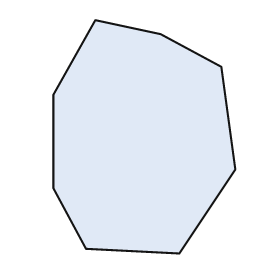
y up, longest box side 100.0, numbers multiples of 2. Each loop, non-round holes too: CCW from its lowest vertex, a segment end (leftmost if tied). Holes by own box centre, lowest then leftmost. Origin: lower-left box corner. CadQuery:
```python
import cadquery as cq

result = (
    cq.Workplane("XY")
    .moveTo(54.0, 0.0)
    .lineTo(78.0, 36.0)
    .lineTo(72.0, 80.0)
    .lineTo(46.0, 94.0)
    .lineTo(18.0, 100.0)
    .lineTo(0.0, 68.0)
    .lineTo(0.0, 28.0)
    .lineTo(14.0, 2.0)
    .close()
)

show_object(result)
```